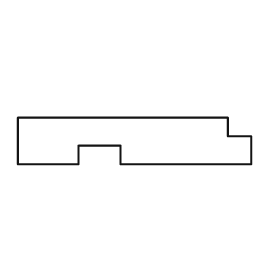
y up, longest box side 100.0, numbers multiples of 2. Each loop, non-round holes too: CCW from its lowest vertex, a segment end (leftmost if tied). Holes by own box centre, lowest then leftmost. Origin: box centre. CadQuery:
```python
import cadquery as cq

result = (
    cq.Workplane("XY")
    .moveTo(-50.0, -10.0)
    .lineTo(-24.0, -10.0)
    .lineTo(-24.0, -2.0)
    .lineTo(-6.0, -2.0)
    .lineTo(-6.0, -10.0)
    .lineTo(50.0, -10.0)
    .lineTo(50.0, 2.0)
    .lineTo(40.0, 2.0)
    .lineTo(40.0, 10.0)
    .lineTo(-50.0, 10.0)
    .close()
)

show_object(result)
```